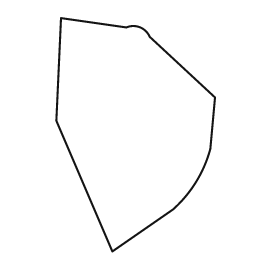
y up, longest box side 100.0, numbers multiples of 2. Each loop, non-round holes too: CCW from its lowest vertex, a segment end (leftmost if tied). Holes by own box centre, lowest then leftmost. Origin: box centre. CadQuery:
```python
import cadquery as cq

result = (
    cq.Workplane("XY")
    .moveTo(-10.0, -50.0)
    .lineTo(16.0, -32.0)
    .threePointArc((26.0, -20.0), (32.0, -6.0))
    .lineTo(34.0, 16.0)
    .lineTo(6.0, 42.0)
    .threePointArc((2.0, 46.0), (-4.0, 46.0))
    .lineTo(-32.0, 50.0)
    .lineTo(-34.0, 6.0)
    .close()
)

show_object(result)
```